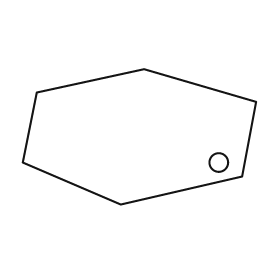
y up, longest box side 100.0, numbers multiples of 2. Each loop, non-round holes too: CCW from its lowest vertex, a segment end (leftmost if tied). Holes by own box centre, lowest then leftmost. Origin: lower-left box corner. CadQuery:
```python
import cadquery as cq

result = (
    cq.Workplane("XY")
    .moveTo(42.0, 0.0)
    .lineTo(94.0, 12.0)
    .lineTo(100.0, 44.0)
    .lineTo(52.0, 58.0)
    .lineTo(6.0, 48.0)
    .lineTo(0.0, 18.0)
    .close()
    .moveTo(84.0, 18.0)
    .circle(4.0)
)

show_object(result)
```